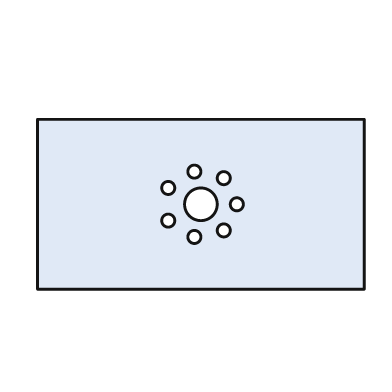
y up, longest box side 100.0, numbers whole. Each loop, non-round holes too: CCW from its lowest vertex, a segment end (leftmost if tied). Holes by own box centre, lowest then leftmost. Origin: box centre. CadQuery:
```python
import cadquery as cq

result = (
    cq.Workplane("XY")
    .moveTo(-50.0, -26.0)
    .lineTo(50.0, -26.0)
    .lineTo(50.0, 26.0)
    .lineTo(-50.0, 26.0)
    .close()
    .moveTo(-2.0, -10.0)
    .circle(2.0)
    .moveTo(7.0, -8.0)
    .circle(2.0)
    .moveTo(-10.0, -5.0)
    .circle(2.0)
    .moveTo(0.0, 0.0)
    .circle(5.0)
    .moveTo(11.0, 0.0)
    .circle(2.0)
    .moveTo(-10.0, 5.0)
    .circle(2.0)
    .moveTo(7.0, 8.0)
    .circle(2.0)
    .moveTo(-2.0, 10.0)
    .circle(2.0)
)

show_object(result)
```